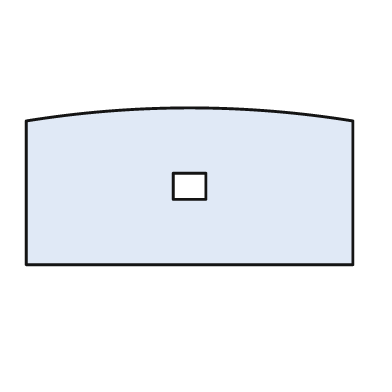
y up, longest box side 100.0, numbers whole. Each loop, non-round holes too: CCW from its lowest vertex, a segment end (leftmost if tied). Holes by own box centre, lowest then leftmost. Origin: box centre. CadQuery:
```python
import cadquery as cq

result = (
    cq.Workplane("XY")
    .moveTo(-50.0, -24.0)
    .lineTo(50.0, -24.0)
    .lineTo(50.0, 20.0)
    .threePointArc((0.0, 24.0), (-50.0, 20.0))
    .close()
    .moveTo(-5.0, -4.0)
    .lineTo(5.0, -4.0)
    .lineTo(5.0, 4.0)
    .lineTo(-5.0, 4.0)
    .close()
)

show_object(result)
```